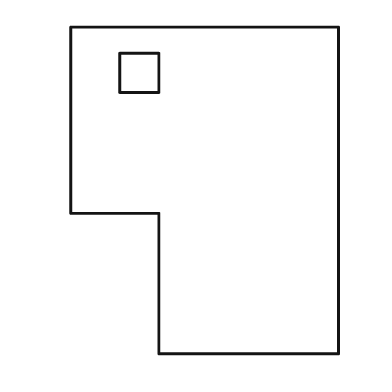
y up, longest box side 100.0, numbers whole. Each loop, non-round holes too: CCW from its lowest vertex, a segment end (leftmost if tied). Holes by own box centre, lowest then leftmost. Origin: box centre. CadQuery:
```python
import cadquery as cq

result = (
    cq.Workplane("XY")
    .moveTo(-14.0, -50.0)
    .lineTo(41.0, -50.0)
    .lineTo(41.0, 50.0)
    .lineTo(-41.0, 50.0)
    .lineTo(-41.0, -7.0)
    .lineTo(-14.0, -7.0)
    .close()
    .moveTo(-26.0, 30.0)
    .lineTo(-14.0, 30.0)
    .lineTo(-14.0, 42.0)
    .lineTo(-26.0, 42.0)
    .close()
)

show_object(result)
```